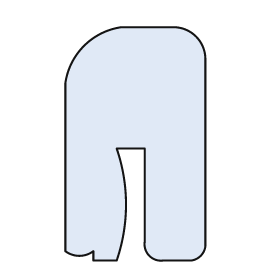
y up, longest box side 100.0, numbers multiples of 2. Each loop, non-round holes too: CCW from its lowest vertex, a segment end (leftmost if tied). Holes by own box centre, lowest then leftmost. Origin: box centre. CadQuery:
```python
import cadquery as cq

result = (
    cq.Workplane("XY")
    .moveTo(-18.0, -50.0)
    .lineTo(-8.0, -50.0)
    .threePointArc((-4.0, -26.0), (-8.0, -2.0))
    .lineTo(4.0, -2.0)
    .lineTo(4.0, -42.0)
    .threePointArc((6.0, -48.0), (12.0, -50.0))
    .lineTo(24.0, -50.0)
    .threePointArc((28.0, -48.0), (30.0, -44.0))
    .lineTo(30.0, 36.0)
    .threePointArc((26.0, 46.0), (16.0, 50.0))
    .lineTo(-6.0, 50.0)
    .threePointArc((-22.0, 42.0), (-30.0, 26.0))
    .lineTo(-30.0, -46.0)
    .threePointArc((-24.0, -48.0), (-18.0, -46.0))
    .close()
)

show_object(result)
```